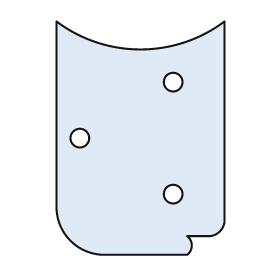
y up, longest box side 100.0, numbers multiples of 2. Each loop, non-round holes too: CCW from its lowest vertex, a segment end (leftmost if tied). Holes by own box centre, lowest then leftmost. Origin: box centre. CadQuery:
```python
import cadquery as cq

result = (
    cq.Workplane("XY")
    .moveTo(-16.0, -50.0)
    .lineTo(20.0, -50.0)
    .threePointArc((22.0, -46.0), (20.0, -42.0))
    .lineTo(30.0, -42.0)
    .threePointArc((34.0, -40.0), (36.0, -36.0))
    .lineTo(36.0, 50.0)
    .threePointArc((0.0, 38.0), (-36.0, 50.0))
    .lineTo(-36.0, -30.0)
    .threePointArc((-30.0, -44.0), (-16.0, -50.0))
    .close()
    .moveTo(14.0, -24.0)
    .circle(4.0)
    .moveTo(-26.0, 0.0)
    .circle(4.0)
    .moveTo(14.0, 24.0)
    .circle(4.0)
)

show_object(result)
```